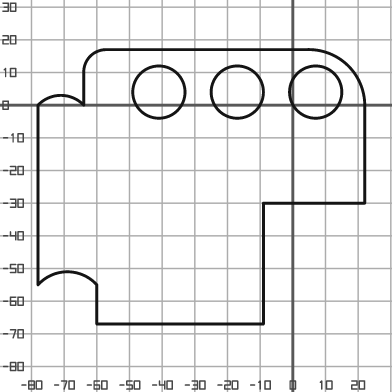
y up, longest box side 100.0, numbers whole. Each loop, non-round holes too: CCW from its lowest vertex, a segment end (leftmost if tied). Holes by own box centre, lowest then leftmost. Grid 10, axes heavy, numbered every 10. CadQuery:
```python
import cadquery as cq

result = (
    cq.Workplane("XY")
    .moveTo(-60.0, -67.0)
    .lineTo(-9.0, -67.0)
    .lineTo(-9.0, -30.0)
    .lineTo(22.0, -30.0)
    .lineTo(22.0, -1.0)
    .threePointArc((17.0, 12.0), (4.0, 17.0))
    .lineTo(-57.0, 17.0)
    .threePointArc((-62.0, 15.0), (-64.0, 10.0))
    .lineTo(-64.0, 0.0)
    .threePointArc((-71.0, 3.0), (-78.0, 0.0))
    .lineTo(-78.0, -55.0)
    .threePointArc((-69.0, -51.0), (-60.0, -55.0))
    .close()
    .moveTo(-41.0, 4.0)
    .circle(8.0)
    .moveTo(-17.0, 4.0)
    .circle(8.0)
    .moveTo(7.0, 4.0)
    .circle(8.0)
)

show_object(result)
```